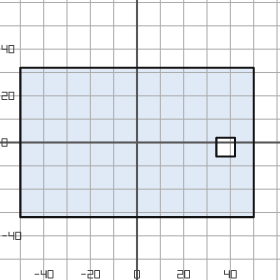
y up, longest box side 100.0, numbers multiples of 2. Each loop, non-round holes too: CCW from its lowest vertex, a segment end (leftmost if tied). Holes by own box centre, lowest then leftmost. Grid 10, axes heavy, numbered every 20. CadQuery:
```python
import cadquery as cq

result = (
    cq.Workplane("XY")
    .moveTo(-50.0, -32.0)
    .lineTo(50.0, -32.0)
    .lineTo(50.0, 32.0)
    .lineTo(-50.0, 32.0)
    .close()
    .moveTo(34.0, -6.0)
    .lineTo(42.0, -6.0)
    .lineTo(42.0, 2.0)
    .lineTo(34.0, 2.0)
    .close()
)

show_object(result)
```